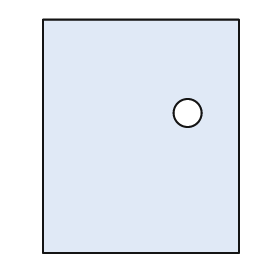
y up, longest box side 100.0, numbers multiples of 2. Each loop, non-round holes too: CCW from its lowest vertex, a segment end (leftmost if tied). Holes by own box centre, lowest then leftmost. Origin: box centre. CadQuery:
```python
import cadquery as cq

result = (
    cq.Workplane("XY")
    .moveTo(-42.0, -50.0)
    .lineTo(42.0, -50.0)
    .lineTo(42.0, 50.0)
    .lineTo(-42.0, 50.0)
    .close()
    .moveTo(20.0, 10.0)
    .circle(6.0)
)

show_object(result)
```